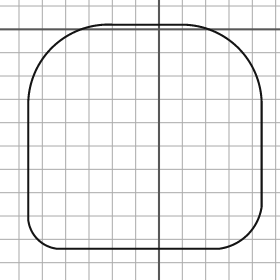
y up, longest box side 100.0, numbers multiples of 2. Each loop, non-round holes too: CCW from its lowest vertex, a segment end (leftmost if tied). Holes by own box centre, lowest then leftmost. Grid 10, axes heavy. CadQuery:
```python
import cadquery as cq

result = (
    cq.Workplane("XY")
    .moveTo(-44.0, -94.0)
    .lineTo(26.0, -94.0)
    .threePointArc((38.0, -88.0), (44.0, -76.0))
    .lineTo(44.0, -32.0)
    .threePointArc((34.0, -8.0), (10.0, 2.0))
    .lineTo(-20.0, 2.0)
    .threePointArc((-46.0, -8.0), (-56.0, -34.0))
    .lineTo(-56.0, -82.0)
    .threePointArc((-52.0, -90.0), (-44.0, -94.0))
    .close()
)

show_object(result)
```